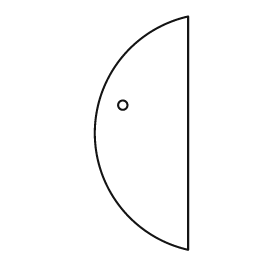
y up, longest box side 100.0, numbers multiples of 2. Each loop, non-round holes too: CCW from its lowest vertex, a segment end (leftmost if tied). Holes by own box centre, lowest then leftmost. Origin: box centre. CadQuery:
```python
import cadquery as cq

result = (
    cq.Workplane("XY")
    .moveTo(20.0, -50.0)
    .lineTo(20.0, 50.0)
    .threePointArc((-20.0, 0.0), (20.0, -50.0))
    .close()
    .moveTo(-8.0, 12.0)
    .circle(2.0)
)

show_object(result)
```